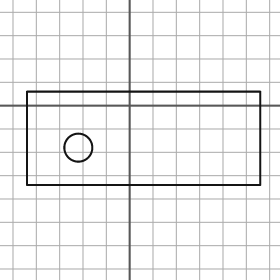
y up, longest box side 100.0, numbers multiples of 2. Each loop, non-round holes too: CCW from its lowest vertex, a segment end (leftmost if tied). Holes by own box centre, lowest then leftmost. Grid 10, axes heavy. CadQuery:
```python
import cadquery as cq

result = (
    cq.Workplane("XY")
    .moveTo(-44.0, -34.0)
    .lineTo(56.0, -34.0)
    .lineTo(56.0, 6.0)
    .lineTo(-44.0, 6.0)
    .close()
    .moveTo(-22.0, -18.0)
    .circle(6.0)
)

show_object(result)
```